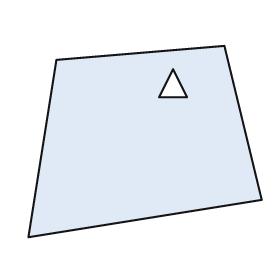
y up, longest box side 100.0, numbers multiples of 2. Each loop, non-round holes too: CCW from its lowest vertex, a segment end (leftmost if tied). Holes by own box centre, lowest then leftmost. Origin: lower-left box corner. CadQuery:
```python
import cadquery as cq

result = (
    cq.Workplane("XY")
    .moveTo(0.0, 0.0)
    .lineTo(100.0, 16.0)
    .lineTo(84.0, 82.0)
    .lineTo(12.0, 76.0)
    .close()
    .moveTo(56.0, 60.0)
    .lineTo(68.0, 60.0)
    .lineTo(62.0, 72.0)
    .close()
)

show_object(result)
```